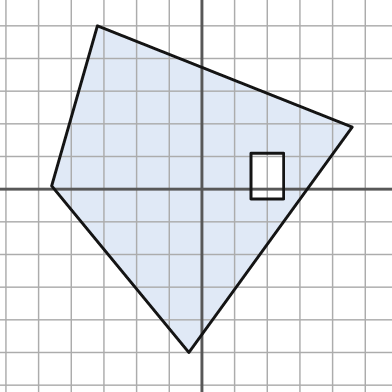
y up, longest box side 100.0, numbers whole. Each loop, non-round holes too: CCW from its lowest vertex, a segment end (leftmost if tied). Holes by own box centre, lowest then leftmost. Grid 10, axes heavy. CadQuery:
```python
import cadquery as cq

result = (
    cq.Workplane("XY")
    .moveTo(-4.0, -50.0)
    .lineTo(46.0, 19.0)
    .lineTo(-32.0, 50.0)
    .lineTo(-46.0, 1.0)
    .close()
    .moveTo(15.0, -3.0)
    .lineTo(25.0, -3.0)
    .lineTo(25.0, 11.0)
    .lineTo(15.0, 11.0)
    .close()
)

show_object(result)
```